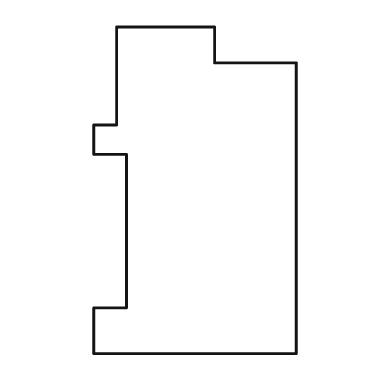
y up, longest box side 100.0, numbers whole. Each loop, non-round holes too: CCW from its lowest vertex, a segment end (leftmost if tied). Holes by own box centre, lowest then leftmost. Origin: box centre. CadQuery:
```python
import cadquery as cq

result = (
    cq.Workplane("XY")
    .moveTo(-31.0, -50.0)
    .lineTo(31.0, -50.0)
    .lineTo(31.0, 39.0)
    .lineTo(6.0, 39.0)
    .lineTo(6.0, 50.0)
    .lineTo(-24.0, 50.0)
    .lineTo(-24.0, 20.0)
    .lineTo(-31.0, 20.0)
    .lineTo(-31.0, 11.0)
    .lineTo(-21.0, 11.0)
    .lineTo(-21.0, -36.0)
    .lineTo(-31.0, -36.0)
    .close()
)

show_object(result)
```